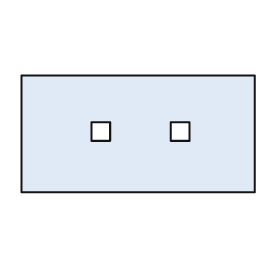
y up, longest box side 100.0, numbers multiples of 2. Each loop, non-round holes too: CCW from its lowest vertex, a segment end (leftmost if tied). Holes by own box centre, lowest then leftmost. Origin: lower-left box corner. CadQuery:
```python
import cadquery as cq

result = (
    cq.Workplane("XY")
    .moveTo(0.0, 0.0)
    .lineTo(100.0, 0.0)
    .lineTo(100.0, 50.0)
    .lineTo(0.0, 50.0)
    .close()
    .moveTo(30.0, 22.0)
    .lineTo(38.0, 22.0)
    .lineTo(38.0, 30.0)
    .lineTo(30.0, 30.0)
    .close()
    .moveTo(64.0, 22.0)
    .lineTo(72.0, 22.0)
    .lineTo(72.0, 30.0)
    .lineTo(64.0, 30.0)
    .close()
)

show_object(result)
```